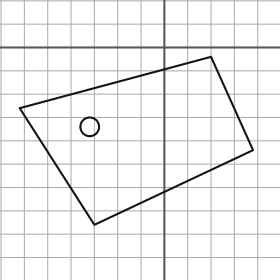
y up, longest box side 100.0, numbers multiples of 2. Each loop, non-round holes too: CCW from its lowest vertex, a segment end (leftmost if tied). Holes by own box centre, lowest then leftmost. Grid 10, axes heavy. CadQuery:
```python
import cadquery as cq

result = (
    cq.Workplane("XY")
    .moveTo(-30.0, -76.0)
    .lineTo(38.0, -44.0)
    .lineTo(20.0, -4.0)
    .lineTo(-62.0, -26.0)
    .close()
    .moveTo(-32.0, -34.0)
    .circle(4.0)
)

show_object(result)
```